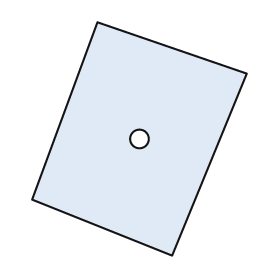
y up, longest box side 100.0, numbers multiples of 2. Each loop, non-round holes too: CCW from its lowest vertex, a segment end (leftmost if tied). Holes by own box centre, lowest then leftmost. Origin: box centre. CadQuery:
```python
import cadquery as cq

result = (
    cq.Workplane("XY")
    .moveTo(14.0, -50.0)
    .lineTo(46.0, 28.0)
    .lineTo(-18.0, 50.0)
    .lineTo(-46.0, -26.0)
    .close()
    .moveTo(0.0, 0.0)
    .circle(4.0)
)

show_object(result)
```